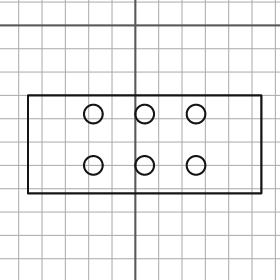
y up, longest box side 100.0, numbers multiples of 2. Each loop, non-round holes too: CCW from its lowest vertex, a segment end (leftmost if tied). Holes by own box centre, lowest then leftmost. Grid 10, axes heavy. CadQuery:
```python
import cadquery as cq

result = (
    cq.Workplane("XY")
    .moveTo(-46.0, -72.0)
    .lineTo(54.0, -72.0)
    .lineTo(54.0, -30.0)
    .lineTo(-46.0, -30.0)
    .close()
    .moveTo(-18.0, -60.0)
    .circle(4.0)
    .moveTo(4.0, -60.0)
    .circle(4.0)
    .moveTo(26.0, -60.0)
    .circle(4.0)
    .moveTo(-18.0, -38.0)
    .circle(4.0)
    .moveTo(4.0, -38.0)
    .circle(4.0)
    .moveTo(26.0, -38.0)
    .circle(4.0)
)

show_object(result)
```